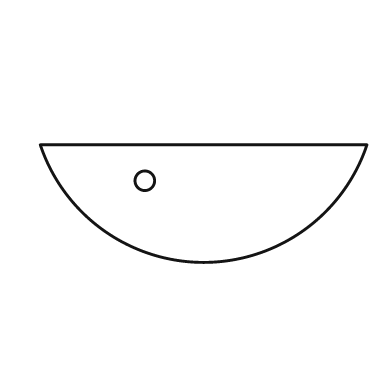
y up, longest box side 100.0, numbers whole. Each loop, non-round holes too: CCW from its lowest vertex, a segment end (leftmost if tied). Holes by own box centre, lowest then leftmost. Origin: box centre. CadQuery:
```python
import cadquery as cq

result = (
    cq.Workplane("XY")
    .moveTo(-50.0, 18.0)
    .threePointArc((0.0, -18.0), (50.0, 18.0))
    .close()
    .moveTo(-18.0, 7.0)
    .circle(3.0)
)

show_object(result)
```